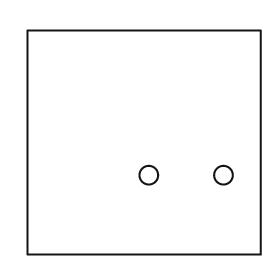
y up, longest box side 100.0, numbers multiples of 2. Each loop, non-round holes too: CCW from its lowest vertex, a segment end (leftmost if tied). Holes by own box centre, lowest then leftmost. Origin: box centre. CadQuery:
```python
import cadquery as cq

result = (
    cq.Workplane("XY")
    .moveTo(-50.0, -48.0)
    .lineTo(50.0, -48.0)
    .lineTo(50.0, 48.0)
    .lineTo(-50.0, 48.0)
    .close()
    .moveTo(2.0, -14.0)
    .circle(4.0)
    .moveTo(34.0, -14.0)
    .circle(4.0)
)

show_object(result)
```